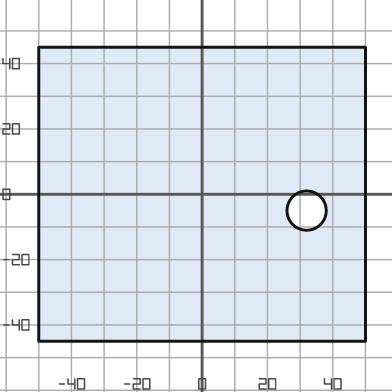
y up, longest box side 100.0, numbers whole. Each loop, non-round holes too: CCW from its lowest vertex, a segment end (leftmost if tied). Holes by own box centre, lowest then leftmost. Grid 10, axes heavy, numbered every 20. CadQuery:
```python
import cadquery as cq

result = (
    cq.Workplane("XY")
    .moveTo(-50.0, -45.0)
    .lineTo(50.0, -45.0)
    .lineTo(50.0, 45.0)
    .lineTo(-50.0, 45.0)
    .close()
    .moveTo(32.0, -5.0)
    .circle(6.0)
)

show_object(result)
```